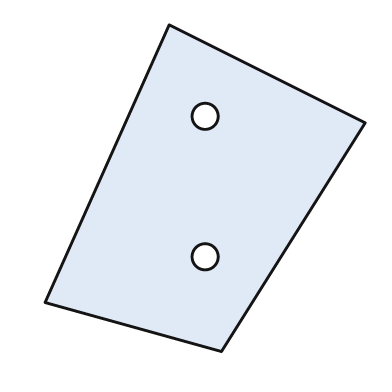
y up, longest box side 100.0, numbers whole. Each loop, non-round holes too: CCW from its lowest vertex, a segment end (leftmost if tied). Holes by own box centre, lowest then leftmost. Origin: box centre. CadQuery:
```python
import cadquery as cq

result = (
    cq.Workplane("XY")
    .moveTo(5.0, -50.0)
    .lineTo(49.0, 20.0)
    .lineTo(-11.0, 50.0)
    .lineTo(-49.0, -35.0)
    .close()
    .moveTo(0.0, -21.0)
    .circle(4.0)
    .moveTo(0.0, 22.0)
    .circle(4.0)
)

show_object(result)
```